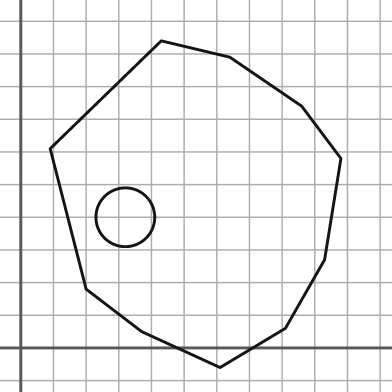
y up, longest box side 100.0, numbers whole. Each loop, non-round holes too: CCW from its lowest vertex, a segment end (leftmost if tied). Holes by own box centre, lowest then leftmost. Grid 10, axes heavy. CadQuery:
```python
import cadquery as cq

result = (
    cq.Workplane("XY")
    .moveTo(61.0, -6.0)
    .lineTo(81.0, 6.0)
    .lineTo(93.0, 27.0)
    .lineTo(98.0, 58.0)
    .lineTo(86.0, 74.0)
    .lineTo(64.0, 89.0)
    .lineTo(43.0, 94.0)
    .lineTo(9.0, 61.0)
    .lineTo(20.0, 18.0)
    .lineTo(37.0, 5.0)
    .close()
    .moveTo(32.0, 40.0)
    .circle(9.0)
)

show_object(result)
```